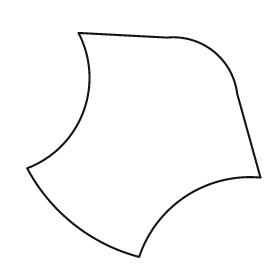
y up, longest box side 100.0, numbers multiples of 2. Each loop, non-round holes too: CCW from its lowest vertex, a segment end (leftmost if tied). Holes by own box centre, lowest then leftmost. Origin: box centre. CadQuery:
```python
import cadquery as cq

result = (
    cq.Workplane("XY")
    .moveTo(-2.0, -48.0)
    .threePointArc((18.0, -22.0), (50.0, -14.0))
    .lineTo(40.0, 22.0)
    .threePointArc((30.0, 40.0), (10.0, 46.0))
    .lineTo(-28.0, 48.0)
    .threePointArc((-26.0, 14.0), (-50.0, -10.0))
    .threePointArc((-30.0, -34.0), (-2.0, -48.0))
    .close()
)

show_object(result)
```